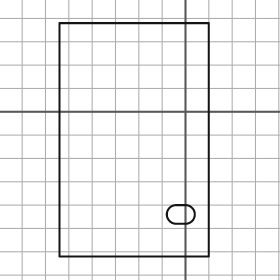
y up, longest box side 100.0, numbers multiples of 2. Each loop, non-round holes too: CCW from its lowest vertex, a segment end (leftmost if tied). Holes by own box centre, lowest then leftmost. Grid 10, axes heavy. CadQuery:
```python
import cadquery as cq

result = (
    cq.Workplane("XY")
    .moveTo(-54.0, -62.0)
    .lineTo(10.0, -62.0)
    .lineTo(10.0, 38.0)
    .lineTo(-54.0, 38.0)
    .close()
    .moveTo(-4.0, -48.0)
    .lineTo(0.0, -48.0)
    .threePointArc((4.0, -44.0), (0.0, -40.0))
    .lineTo(-4.0, -40.0)
    .threePointArc((-8.0, -44.0), (-4.0, -48.0))
    .close()
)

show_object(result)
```